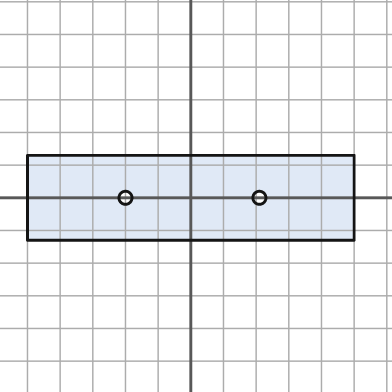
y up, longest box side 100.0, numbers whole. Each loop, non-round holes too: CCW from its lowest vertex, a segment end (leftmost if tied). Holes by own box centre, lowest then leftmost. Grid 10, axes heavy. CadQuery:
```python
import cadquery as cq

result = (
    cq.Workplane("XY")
    .moveTo(-50.0, -13.0)
    .lineTo(50.0, -13.0)
    .lineTo(50.0, 13.0)
    .lineTo(-50.0, 13.0)
    .close()
    .moveTo(-20.0, 0.0)
    .circle(2.0)
    .moveTo(21.0, 0.0)
    .circle(2.0)
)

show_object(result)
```